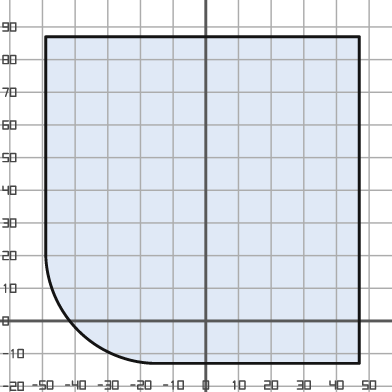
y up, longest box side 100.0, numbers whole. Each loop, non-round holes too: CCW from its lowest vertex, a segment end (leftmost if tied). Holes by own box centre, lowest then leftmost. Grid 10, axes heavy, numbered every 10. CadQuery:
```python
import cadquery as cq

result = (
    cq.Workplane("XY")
    .moveTo(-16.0, -13.0)
    .lineTo(47.0, -13.0)
    .lineTo(47.0, 87.0)
    .lineTo(-49.0, 87.0)
    .lineTo(-49.0, 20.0)
    .threePointArc((-39.0, -3.0), (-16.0, -13.0))
    .close()
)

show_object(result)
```